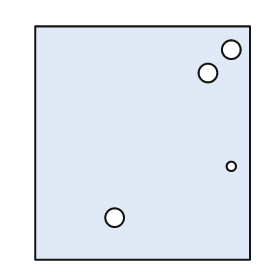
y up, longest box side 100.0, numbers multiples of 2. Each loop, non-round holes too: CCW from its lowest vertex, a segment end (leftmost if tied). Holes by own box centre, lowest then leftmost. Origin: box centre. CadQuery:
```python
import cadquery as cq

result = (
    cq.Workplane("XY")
    .moveTo(-46.0, -50.0)
    .lineTo(46.0, -50.0)
    .lineTo(46.0, 50.0)
    .lineTo(-46.0, 50.0)
    .close()
    .moveTo(-12.0, -32.0)
    .circle(4.0)
    .moveTo(38.0, -10.0)
    .circle(2.0)
    .moveTo(28.0, 30.0)
    .circle(4.0)
    .moveTo(38.0, 40.0)
    .circle(4.0)
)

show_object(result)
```